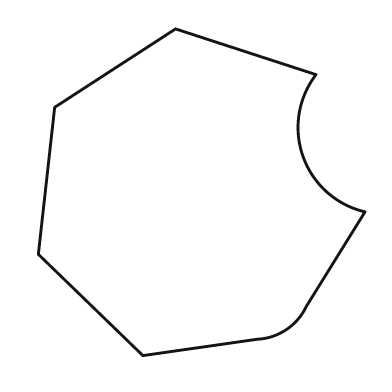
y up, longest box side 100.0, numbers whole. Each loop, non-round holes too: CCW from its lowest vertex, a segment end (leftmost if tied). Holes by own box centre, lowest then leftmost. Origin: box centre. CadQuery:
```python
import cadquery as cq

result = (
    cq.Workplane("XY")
    .moveTo(-18.0, -50.0)
    .lineTo(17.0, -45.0)
    .threePointArc((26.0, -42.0), (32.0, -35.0))
    .lineTo(50.0, -6.0)
    .threePointArc((31.0, 11.0), (35.0, 36.0))
    .lineTo(-8.0, 50.0)
    .lineTo(-45.0, 26.0)
    .lineTo(-50.0, -19.0)
    .close()
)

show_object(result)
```